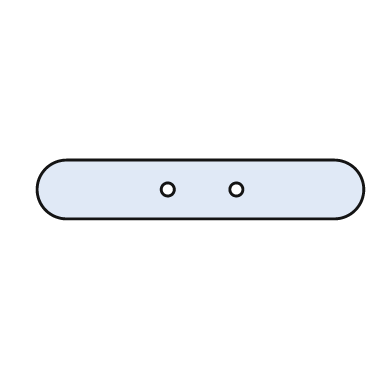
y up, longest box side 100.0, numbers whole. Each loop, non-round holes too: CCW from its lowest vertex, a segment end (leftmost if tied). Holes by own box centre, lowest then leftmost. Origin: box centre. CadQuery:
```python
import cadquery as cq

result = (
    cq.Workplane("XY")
    .moveTo(-41.0, -9.0)
    .lineTo(41.0, -9.0)
    .threePointArc((50.0, 0.0), (41.0, 9.0))
    .lineTo(-41.0, 9.0)
    .threePointArc((-50.0, 0.0), (-41.0, -9.0))
    .close()
    .moveTo(-10.0, 0.0)
    .circle(2.0)
    .moveTo(11.0, 0.0)
    .circle(2.0)
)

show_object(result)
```